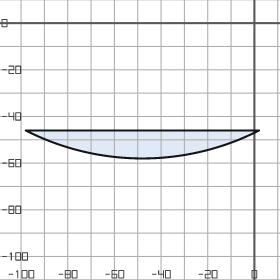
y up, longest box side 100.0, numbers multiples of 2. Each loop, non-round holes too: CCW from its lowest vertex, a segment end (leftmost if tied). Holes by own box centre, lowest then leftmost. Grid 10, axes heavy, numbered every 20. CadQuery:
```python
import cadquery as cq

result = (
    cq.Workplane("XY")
    .moveTo(-98.0, -46.0)
    .threePointArc((-48.0, -58.0), (2.0, -46.0))
    .close()
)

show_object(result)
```